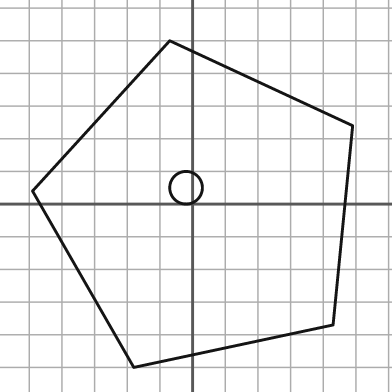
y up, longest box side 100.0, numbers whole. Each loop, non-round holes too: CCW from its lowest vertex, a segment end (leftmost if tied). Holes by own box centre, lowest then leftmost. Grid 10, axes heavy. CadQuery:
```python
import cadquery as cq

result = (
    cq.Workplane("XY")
    .moveTo(-18.0, -50.0)
    .lineTo(43.0, -37.0)
    .lineTo(49.0, 24.0)
    .lineTo(-7.0, 50.0)
    .lineTo(-49.0, 4.0)
    .close()
    .moveTo(-2.0, 5.0)
    .circle(5.0)
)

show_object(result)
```